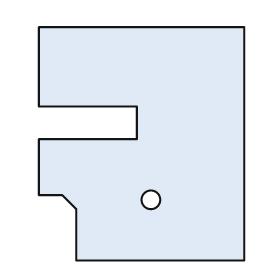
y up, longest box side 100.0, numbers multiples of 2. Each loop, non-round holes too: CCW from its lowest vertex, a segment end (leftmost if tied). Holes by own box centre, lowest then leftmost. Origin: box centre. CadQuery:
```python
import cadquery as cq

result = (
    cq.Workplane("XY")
    .moveTo(-28.0, -50.0)
    .lineTo(44.0, -50.0)
    .lineTo(44.0, 50.0)
    .lineTo(-44.0, 50.0)
    .lineTo(-44.0, 16.0)
    .lineTo(-2.0, 16.0)
    .lineTo(-2.0, 2.0)
    .lineTo(-44.0, 2.0)
    .lineTo(-44.0, -22.0)
    .lineTo(-34.0, -22.0)
    .lineTo(-28.0, -28.0)
    .close()
    .moveTo(4.0, -24.0)
    .circle(4.0)
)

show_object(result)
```